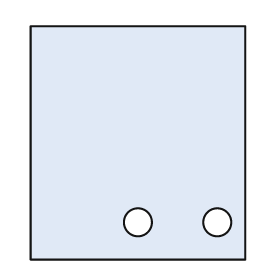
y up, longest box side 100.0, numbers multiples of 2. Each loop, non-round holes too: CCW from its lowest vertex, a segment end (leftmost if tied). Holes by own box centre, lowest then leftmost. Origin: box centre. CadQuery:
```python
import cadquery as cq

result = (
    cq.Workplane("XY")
    .moveTo(-46.0, -50.0)
    .lineTo(46.0, -50.0)
    .lineTo(46.0, 50.0)
    .lineTo(-46.0, 50.0)
    .close()
    .moveTo(0.0, -34.0)
    .circle(6.0)
    .moveTo(34.0, -34.0)
    .circle(6.0)
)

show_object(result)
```